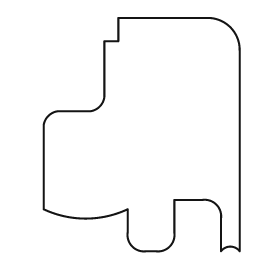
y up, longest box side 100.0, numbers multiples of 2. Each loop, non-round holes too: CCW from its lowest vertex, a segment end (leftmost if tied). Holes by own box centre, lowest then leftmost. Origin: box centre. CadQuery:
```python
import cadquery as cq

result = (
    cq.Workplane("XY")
    .moveTo(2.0, -50.0)
    .lineTo(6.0, -50.0)
    .threePointArc((12.0, -48.0), (14.0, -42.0))
    .lineTo(14.0, -28.0)
    .lineTo(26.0, -28.0)
    .threePointArc((32.0, -30.0), (34.0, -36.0))
    .lineTo(34.0, -50.0)
    .threePointArc((38.0, -48.0), (42.0, -50.0))
    .lineTo(42.0, 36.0)
    .threePointArc((38.0, 46.0), (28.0, 50.0))
    .lineTo(-10.0, 50.0)
    .lineTo(-10.0, 40.0)
    .lineTo(-16.0, 40.0)
    .lineTo(-16.0, 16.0)
    .threePointArc((-18.0, 12.0), (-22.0, 10.0))
    .lineTo(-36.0, 10.0)
    .threePointArc((-40.0, 8.0), (-42.0, 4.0))
    .lineTo(-42.0, -32.0)
    .threePointArc((-24.0, -36.0), (-6.0, -32.0))
    .lineTo(-6.0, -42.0)
    .threePointArc((-4.0, -48.0), (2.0, -50.0))
    .close()
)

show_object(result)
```